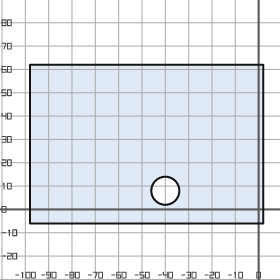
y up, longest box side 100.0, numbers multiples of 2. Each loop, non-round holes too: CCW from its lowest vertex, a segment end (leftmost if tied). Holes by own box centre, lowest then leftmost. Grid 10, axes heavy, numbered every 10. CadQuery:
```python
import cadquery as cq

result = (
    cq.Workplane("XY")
    .moveTo(-98.0, -6.0)
    .lineTo(2.0, -6.0)
    .lineTo(2.0, 62.0)
    .lineTo(-98.0, 62.0)
    .close()
    .moveTo(-40.0, 8.0)
    .circle(6.0)
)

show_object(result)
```